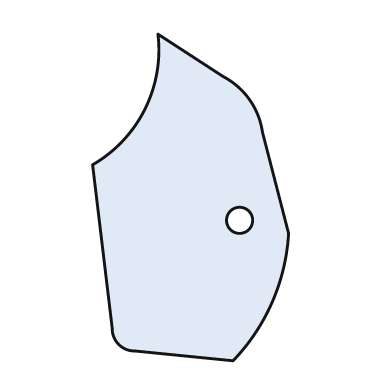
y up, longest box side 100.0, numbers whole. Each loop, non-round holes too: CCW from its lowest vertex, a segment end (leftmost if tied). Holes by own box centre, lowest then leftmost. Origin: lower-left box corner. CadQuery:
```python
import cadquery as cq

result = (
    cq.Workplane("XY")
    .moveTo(43.0, 0.0)
    .threePointArc((55.0, 18.0), (60.0, 39.0))
    .lineTo(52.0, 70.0)
    .threePointArc((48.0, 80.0), (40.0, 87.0))
    .lineTo(20.0, 100.0)
    .threePointArc((16.0, 77.0), (0.0, 60.0))
    .lineTo(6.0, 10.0)
    .threePointArc((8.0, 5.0), (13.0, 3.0))
    .close()
    .moveTo(45.0, 43.0)
    .circle(4.0)
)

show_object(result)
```